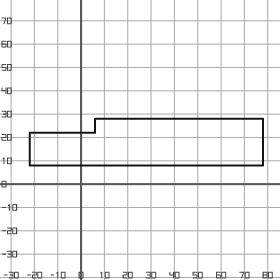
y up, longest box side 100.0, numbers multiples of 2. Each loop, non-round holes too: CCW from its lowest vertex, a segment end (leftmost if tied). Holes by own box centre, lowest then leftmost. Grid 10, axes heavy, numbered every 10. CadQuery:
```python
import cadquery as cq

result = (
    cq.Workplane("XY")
    .moveTo(-22.0, 8.0)
    .lineTo(78.0, 8.0)
    .lineTo(78.0, 28.0)
    .lineTo(6.0, 28.0)
    .lineTo(6.0, 22.0)
    .lineTo(-22.0, 22.0)
    .close()
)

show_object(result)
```